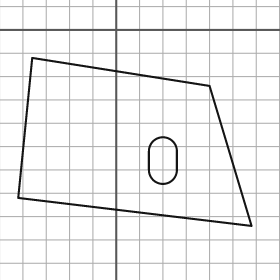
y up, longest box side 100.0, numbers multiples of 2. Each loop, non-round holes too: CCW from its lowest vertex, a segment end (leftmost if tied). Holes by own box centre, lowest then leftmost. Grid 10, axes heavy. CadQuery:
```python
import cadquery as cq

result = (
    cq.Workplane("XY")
    .moveTo(58.0, -84.0)
    .lineTo(40.0, -24.0)
    .lineTo(-36.0, -12.0)
    .lineTo(-42.0, -72.0)
    .close()
    .moveTo(14.0, -60.0)
    .threePointArc((20.0, -66.0), (26.0, -60.0))
    .lineTo(26.0, -52.0)
    .threePointArc((20.0, -46.0), (14.0, -52.0))
    .close()
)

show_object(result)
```